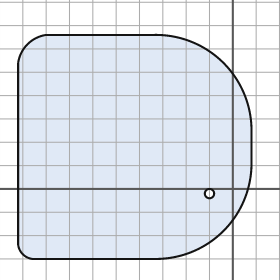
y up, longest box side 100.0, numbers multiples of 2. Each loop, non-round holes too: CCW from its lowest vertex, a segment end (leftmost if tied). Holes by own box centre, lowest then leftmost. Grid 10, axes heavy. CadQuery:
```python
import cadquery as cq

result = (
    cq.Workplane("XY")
    .moveTo(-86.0, -30.0)
    .lineTo(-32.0, -30.0)
    .threePointArc((-4.0, -18.0), (8.0, 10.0))
    .lineTo(8.0, 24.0)
    .threePointArc((-4.0, 54.0), (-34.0, 66.0))
    .lineTo(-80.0, 66.0)
    .threePointArc((-88.0, 62.0), (-92.0, 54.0))
    .lineTo(-92.0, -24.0)
    .threePointArc((-90.0, -28.0), (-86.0, -30.0))
    .close()
    .moveTo(-10.0, -2.0)
    .circle(2.0)
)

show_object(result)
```